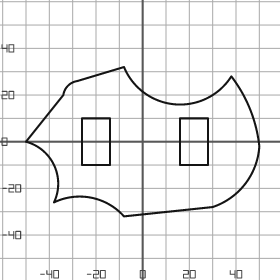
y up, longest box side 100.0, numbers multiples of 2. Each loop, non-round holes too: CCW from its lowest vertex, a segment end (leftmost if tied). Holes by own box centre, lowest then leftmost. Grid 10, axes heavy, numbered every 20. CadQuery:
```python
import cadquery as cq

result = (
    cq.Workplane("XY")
    .moveTo(-8.0, -32.0)
    .lineTo(30.0, -28.0)
    .threePointArc((44.0, -18.0), (50.0, -2.0))
    .threePointArc((46.0, 14.0), (38.0, 28.0))
    .threePointArc((14.0, 16.0), (-8.0, 32.0))
    .lineTo(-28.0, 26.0)
    .threePointArc((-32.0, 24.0), (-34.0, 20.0))
    .lineTo(-50.0, 0.0)
    .threePointArc((-38.0, -10.0), (-38.0, -26.0))
    .threePointArc((-22.0, -24.0), (-8.0, -32.0))
    .close()
    .moveTo(-26.0, -10.0)
    .lineTo(-14.0, -10.0)
    .lineTo(-14.0, 10.0)
    .lineTo(-26.0, 10.0)
    .close()
    .moveTo(16.0, -10.0)
    .lineTo(28.0, -10.0)
    .lineTo(28.0, 10.0)
    .lineTo(16.0, 10.0)
    .close()
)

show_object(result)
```